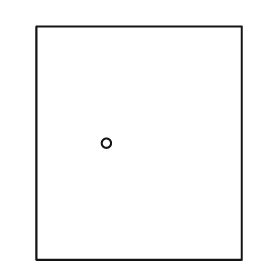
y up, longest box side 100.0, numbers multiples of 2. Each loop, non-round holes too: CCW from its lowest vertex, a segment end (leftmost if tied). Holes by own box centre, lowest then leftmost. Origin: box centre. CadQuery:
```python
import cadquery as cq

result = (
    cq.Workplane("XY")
    .moveTo(-44.0, -50.0)
    .lineTo(44.0, -50.0)
    .lineTo(44.0, 50.0)
    .lineTo(-44.0, 50.0)
    .close()
    .moveTo(-14.0, 0.0)
    .circle(2.0)
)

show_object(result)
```